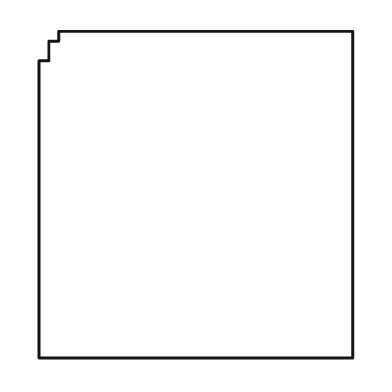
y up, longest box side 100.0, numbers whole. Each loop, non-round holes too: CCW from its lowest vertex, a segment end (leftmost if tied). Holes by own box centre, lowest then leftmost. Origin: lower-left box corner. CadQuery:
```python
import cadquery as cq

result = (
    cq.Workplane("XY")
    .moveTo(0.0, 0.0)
    .lineTo(96.0, 0.0)
    .lineTo(96.0, 100.0)
    .lineTo(6.0, 100.0)
    .lineTo(6.0, 97.0)
    .lineTo(3.0, 97.0)
    .lineTo(3.0, 91.0)
    .lineTo(0.0, 91.0)
    .close()
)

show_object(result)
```